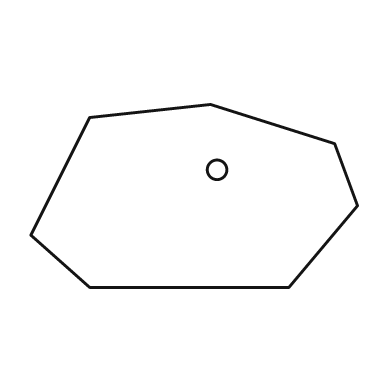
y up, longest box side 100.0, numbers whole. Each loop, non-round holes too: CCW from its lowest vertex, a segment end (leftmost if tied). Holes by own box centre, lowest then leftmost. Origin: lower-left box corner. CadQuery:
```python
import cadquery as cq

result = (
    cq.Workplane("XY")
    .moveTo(18.0, 0.0)
    .lineTo(79.0, 0.0)
    .lineTo(100.0, 25.0)
    .lineTo(93.0, 44.0)
    .lineTo(55.0, 56.0)
    .lineTo(18.0, 52.0)
    .lineTo(0.0, 16.0)
    .close()
    .moveTo(57.0, 36.0)
    .circle(3.0)
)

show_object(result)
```